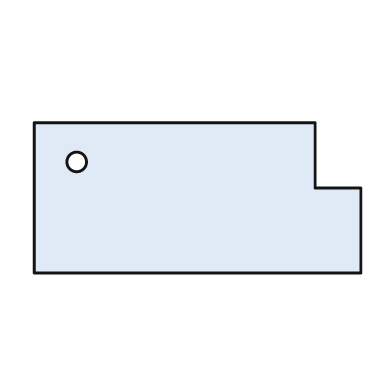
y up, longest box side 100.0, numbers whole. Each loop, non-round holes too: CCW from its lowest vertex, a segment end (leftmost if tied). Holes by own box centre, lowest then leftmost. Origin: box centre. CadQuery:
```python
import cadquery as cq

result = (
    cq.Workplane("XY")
    .moveTo(-50.0, -23.0)
    .lineTo(50.0, -23.0)
    .lineTo(50.0, 3.0)
    .lineTo(36.0, 3.0)
    .lineTo(36.0, 23.0)
    .lineTo(-50.0, 23.0)
    .close()
    .moveTo(-37.0, 11.0)
    .circle(3.0)
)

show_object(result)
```